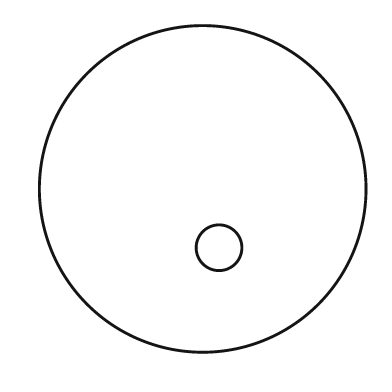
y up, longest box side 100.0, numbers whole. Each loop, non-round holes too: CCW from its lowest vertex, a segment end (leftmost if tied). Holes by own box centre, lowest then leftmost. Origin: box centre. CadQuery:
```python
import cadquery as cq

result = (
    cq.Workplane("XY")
    .moveTo(0.0, 0.0)
    .circle(50.0)
    .moveTo(5.0, -18.0)
    .circle(7.0)
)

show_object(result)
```